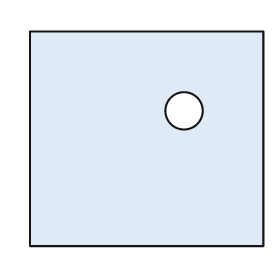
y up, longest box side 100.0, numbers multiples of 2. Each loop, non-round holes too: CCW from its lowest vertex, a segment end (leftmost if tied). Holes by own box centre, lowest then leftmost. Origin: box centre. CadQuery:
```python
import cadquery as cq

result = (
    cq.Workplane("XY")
    .moveTo(-50.0, -46.0)
    .lineTo(50.0, -46.0)
    .lineTo(50.0, 46.0)
    .lineTo(-50.0, 46.0)
    .close()
    .moveTo(16.0, 12.0)
    .circle(8.0)
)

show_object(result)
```